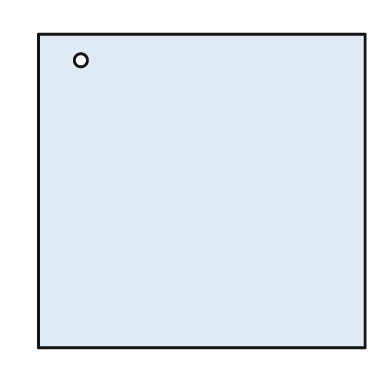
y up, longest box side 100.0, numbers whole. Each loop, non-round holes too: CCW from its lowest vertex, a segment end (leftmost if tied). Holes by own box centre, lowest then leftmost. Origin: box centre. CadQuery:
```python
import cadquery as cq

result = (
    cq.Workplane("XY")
    .moveTo(-50.0, -48.0)
    .lineTo(50.0, -48.0)
    .lineTo(50.0, 48.0)
    .lineTo(-50.0, 48.0)
    .close()
    .moveTo(-37.0, 40.0)
    .circle(2.0)
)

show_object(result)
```